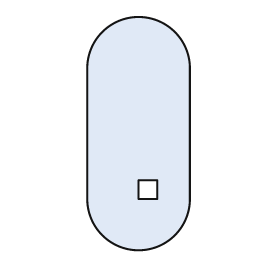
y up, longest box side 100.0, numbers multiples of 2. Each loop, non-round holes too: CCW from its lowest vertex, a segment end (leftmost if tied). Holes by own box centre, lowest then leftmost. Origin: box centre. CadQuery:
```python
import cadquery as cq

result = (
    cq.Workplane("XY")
    .moveTo(-22.0, -28.0)
    .threePointArc((0.0, -50.0), (22.0, -28.0))
    .lineTo(22.0, 28.0)
    .threePointArc((0.0, 50.0), (-22.0, 28.0))
    .close()
    .moveTo(0.0, -28.0)
    .lineTo(8.0, -28.0)
    .lineTo(8.0, -20.0)
    .lineTo(0.0, -20.0)
    .close()
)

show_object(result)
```